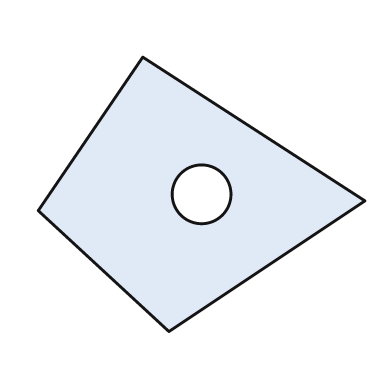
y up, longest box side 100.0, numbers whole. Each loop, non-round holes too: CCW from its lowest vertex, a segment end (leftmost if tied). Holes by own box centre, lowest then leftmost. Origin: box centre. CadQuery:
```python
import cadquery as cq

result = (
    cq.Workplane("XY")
    .moveTo(-10.0, -42.0)
    .lineTo(50.0, -2.0)
    .lineTo(-18.0, 42.0)
    .lineTo(-50.0, -5.0)
    .close()
    .moveTo(0.0, 0.0)
    .circle(9.0)
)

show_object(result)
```